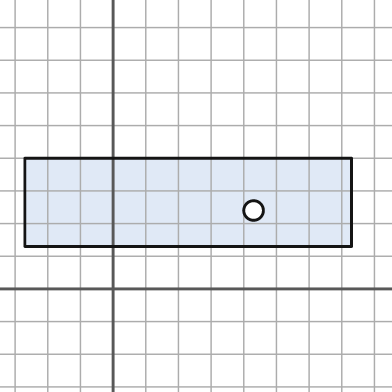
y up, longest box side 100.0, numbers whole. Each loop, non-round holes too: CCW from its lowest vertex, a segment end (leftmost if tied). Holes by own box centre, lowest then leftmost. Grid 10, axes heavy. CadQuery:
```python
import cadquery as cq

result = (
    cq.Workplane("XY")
    .moveTo(-27.0, 13.0)
    .lineTo(73.0, 13.0)
    .lineTo(73.0, 40.0)
    .lineTo(-27.0, 40.0)
    .close()
    .moveTo(43.0, 24.0)
    .circle(3.0)
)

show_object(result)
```